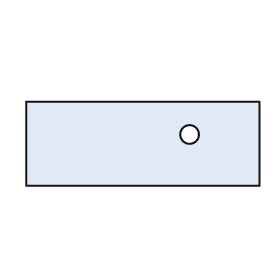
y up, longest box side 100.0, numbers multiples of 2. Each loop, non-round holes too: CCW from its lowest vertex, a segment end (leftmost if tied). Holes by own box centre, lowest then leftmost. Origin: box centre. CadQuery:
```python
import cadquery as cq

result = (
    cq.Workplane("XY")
    .moveTo(-50.0, -18.0)
    .lineTo(50.0, -18.0)
    .lineTo(50.0, 18.0)
    .lineTo(-50.0, 18.0)
    .close()
    .moveTo(20.0, 4.0)
    .circle(4.0)
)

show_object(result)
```